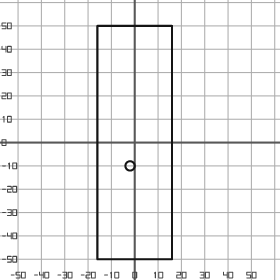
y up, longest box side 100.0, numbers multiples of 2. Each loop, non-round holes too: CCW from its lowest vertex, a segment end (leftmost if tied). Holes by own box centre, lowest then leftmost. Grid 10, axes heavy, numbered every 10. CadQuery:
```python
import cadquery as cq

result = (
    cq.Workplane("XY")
    .moveTo(-16.0, -50.0)
    .lineTo(16.0, -50.0)
    .lineTo(16.0, 50.0)
    .lineTo(-16.0, 50.0)
    .close()
    .moveTo(-2.0, -10.0)
    .circle(2.0)
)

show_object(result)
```